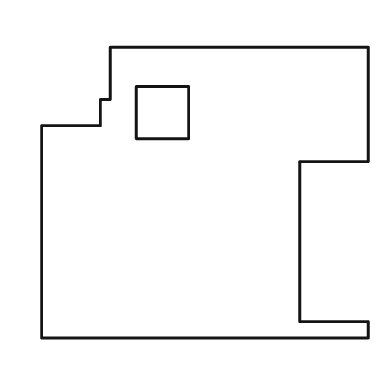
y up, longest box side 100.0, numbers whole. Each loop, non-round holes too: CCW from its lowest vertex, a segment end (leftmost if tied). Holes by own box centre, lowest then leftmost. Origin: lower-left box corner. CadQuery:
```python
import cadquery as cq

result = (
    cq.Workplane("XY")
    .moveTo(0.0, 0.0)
    .lineTo(100.0, 0.0)
    .lineTo(100.0, 5.0)
    .lineTo(79.0, 5.0)
    .lineTo(79.0, 54.0)
    .lineTo(100.0, 54.0)
    .lineTo(100.0, 89.0)
    .lineTo(21.0, 89.0)
    .lineTo(21.0, 73.0)
    .lineTo(18.0, 73.0)
    .lineTo(18.0, 65.0)
    .lineTo(0.0, 65.0)
    .close()
    .moveTo(29.0, 61.0)
    .lineTo(45.0, 61.0)
    .lineTo(45.0, 77.0)
    .lineTo(29.0, 77.0)
    .close()
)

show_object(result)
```